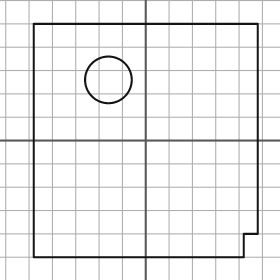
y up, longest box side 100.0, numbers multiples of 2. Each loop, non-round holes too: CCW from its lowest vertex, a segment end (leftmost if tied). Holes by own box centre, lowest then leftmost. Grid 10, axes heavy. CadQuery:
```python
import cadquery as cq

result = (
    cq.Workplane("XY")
    .moveTo(-48.0, -50.0)
    .lineTo(42.0, -50.0)
    .lineTo(42.0, -40.0)
    .lineTo(48.0, -40.0)
    .lineTo(48.0, 50.0)
    .lineTo(-48.0, 50.0)
    .close()
    .moveTo(-16.0, 26.0)
    .circle(10.0)
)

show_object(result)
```